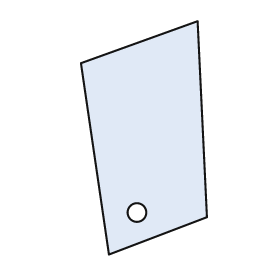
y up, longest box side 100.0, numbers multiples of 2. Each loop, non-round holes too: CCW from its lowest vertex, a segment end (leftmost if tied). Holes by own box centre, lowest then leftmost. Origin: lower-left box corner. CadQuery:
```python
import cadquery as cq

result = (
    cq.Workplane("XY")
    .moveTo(12.0, 0.0)
    .lineTo(54.0, 16.0)
    .lineTo(50.0, 100.0)
    .lineTo(0.0, 82.0)
    .close()
    .moveTo(24.0, 18.0)
    .circle(4.0)
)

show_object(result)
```